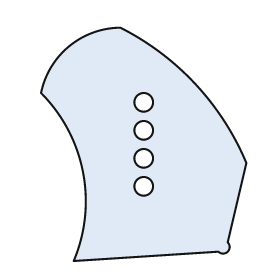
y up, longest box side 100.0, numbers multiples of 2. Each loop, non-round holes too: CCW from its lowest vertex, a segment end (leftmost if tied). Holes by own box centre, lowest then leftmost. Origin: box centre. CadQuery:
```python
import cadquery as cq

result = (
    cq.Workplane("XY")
    .moveTo(-30.0, -50.0)
    .lineTo(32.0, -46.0)
    .threePointArc((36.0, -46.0), (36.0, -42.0))
    .lineTo(44.0, -8.0)
    .threePointArc((22.0, 26.0), (-10.0, 50.0))
    .threePointArc((-32.0, 42.0), (-44.0, 22.0))
    .threePointArc((-26.0, -12.0), (-30.0, -50.0))
    .close()
    .moveTo(0.0, -18.0)
    .circle(4.0)
    .moveTo(0.0, -6.0)
    .circle(4.0)
    .moveTo(0.0, 6.0)
    .circle(4.0)
    .moveTo(0.0, 18.0)
    .circle(4.0)
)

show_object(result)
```